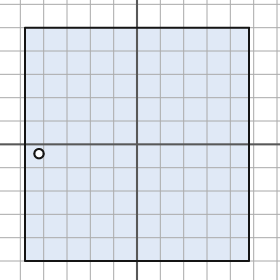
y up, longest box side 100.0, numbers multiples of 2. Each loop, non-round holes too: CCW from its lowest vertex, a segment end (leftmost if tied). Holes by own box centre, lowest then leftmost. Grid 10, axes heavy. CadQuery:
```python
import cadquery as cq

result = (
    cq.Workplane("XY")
    .moveTo(-48.0, -50.0)
    .lineTo(48.0, -50.0)
    .lineTo(48.0, 50.0)
    .lineTo(-48.0, 50.0)
    .close()
    .moveTo(-42.0, -4.0)
    .circle(2.0)
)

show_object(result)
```